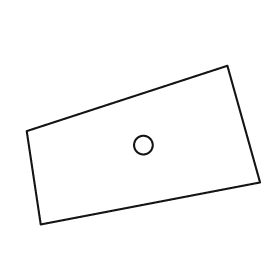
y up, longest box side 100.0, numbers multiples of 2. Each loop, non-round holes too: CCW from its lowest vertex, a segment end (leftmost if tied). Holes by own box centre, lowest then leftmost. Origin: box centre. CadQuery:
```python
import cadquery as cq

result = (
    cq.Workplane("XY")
    .moveTo(-44.0, -34.0)
    .lineTo(50.0, -16.0)
    .lineTo(36.0, 34.0)
    .lineTo(-50.0, 6.0)
    .close()
    .moveTo(0.0, 0.0)
    .circle(4.0)
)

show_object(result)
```